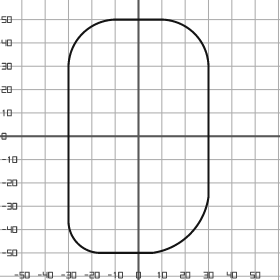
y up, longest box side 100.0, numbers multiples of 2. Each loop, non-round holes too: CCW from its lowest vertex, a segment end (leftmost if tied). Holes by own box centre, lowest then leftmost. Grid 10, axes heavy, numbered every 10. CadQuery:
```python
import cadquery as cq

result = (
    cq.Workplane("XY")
    .moveTo(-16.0, -50.0)
    .lineTo(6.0, -50.0)
    .threePointArc((22.0, -42.0), (30.0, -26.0))
    .lineTo(30.0, 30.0)
    .threePointArc((24.0, 44.0), (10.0, 50.0))
    .lineTo(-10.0, 50.0)
    .threePointArc((-24.0, 44.0), (-30.0, 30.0))
    .lineTo(-30.0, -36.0)
    .threePointArc((-26.0, -46.0), (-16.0, -50.0))
    .close()
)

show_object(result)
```